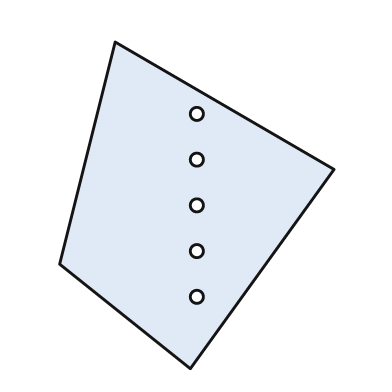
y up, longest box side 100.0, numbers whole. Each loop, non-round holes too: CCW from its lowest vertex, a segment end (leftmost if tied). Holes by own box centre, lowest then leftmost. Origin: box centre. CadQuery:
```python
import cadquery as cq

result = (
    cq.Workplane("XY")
    .moveTo(-2.0, -50.0)
    .lineTo(42.0, 11.0)
    .lineTo(-25.0, 50.0)
    .lineTo(-42.0, -18.0)
    .close()
    .moveTo(0.0, -28.0)
    .circle(2.0)
    .moveTo(0.0, -14.0)
    .circle(2.0)
    .moveTo(0.0, 0.0)
    .circle(2.0)
    .moveTo(0.0, 14.0)
    .circle(2.0)
    .moveTo(0.0, 28.0)
    .circle(2.0)
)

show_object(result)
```